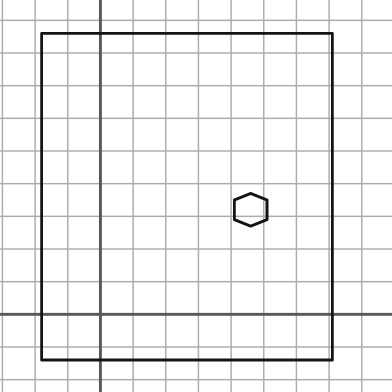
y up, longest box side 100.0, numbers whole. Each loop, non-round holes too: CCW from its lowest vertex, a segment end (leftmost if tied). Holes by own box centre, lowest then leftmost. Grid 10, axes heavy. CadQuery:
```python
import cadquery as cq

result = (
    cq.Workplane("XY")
    .moveTo(-18.0, -14.0)
    .lineTo(71.0, -14.0)
    .lineTo(71.0, 86.0)
    .lineTo(-18.0, 86.0)
    .close()
    .moveTo(46.0, 27.0)
    .lineTo(51.0, 29.0)
    .lineTo(51.0, 35.0)
    .lineTo(46.0, 37.0)
    .lineTo(41.0, 35.0)
    .lineTo(41.0, 29.0)
    .close()
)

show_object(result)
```